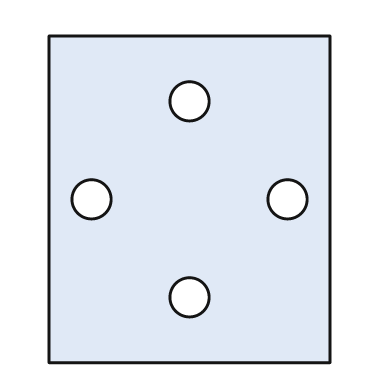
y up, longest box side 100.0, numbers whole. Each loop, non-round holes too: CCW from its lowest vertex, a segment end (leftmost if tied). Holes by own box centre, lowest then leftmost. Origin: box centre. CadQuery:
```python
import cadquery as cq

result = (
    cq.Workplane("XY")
    .moveTo(-43.0, -50.0)
    .lineTo(43.0, -50.0)
    .lineTo(43.0, 50.0)
    .lineTo(-43.0, 50.0)
    .close()
    .moveTo(0.0, -30.0)
    .circle(6.0)
    .moveTo(-30.0, 0.0)
    .circle(6.0)
    .moveTo(30.0, 0.0)
    .circle(6.0)
    .moveTo(0.0, 30.0)
    .circle(6.0)
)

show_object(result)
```